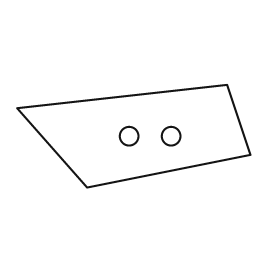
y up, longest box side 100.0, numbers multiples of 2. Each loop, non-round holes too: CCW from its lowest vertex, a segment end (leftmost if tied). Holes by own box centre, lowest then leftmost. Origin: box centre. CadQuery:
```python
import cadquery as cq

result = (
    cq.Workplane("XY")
    .moveTo(-20.0, -22.0)
    .lineTo(50.0, -8.0)
    .lineTo(40.0, 22.0)
    .lineTo(-50.0, 12.0)
    .close()
    .moveTo(-2.0, 0.0)
    .circle(4.0)
    .moveTo(16.0, 0.0)
    .circle(4.0)
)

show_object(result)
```